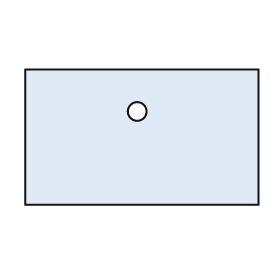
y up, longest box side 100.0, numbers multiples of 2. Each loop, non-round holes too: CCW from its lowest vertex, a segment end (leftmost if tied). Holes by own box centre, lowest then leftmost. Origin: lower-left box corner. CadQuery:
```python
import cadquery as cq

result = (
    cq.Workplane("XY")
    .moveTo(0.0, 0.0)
    .lineTo(100.0, 0.0)
    .lineTo(100.0, 58.0)
    .lineTo(0.0, 58.0)
    .close()
    .moveTo(48.0, 40.0)
    .circle(4.0)
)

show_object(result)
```